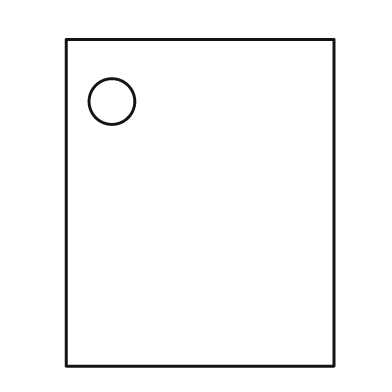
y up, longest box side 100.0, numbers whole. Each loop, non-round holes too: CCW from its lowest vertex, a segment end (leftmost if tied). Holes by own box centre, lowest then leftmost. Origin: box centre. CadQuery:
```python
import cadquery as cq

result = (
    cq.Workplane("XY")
    .moveTo(-41.0, -50.0)
    .lineTo(41.0, -50.0)
    .lineTo(41.0, 50.0)
    .lineTo(-41.0, 50.0)
    .close()
    .moveTo(-27.0, 31.0)
    .circle(7.0)
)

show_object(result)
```